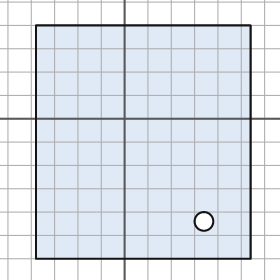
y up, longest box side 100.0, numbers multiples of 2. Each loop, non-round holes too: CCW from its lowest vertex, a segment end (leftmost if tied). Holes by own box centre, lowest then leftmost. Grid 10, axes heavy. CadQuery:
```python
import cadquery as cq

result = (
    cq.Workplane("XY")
    .moveTo(-38.0, -60.0)
    .lineTo(54.0, -60.0)
    .lineTo(54.0, 40.0)
    .lineTo(-38.0, 40.0)
    .close()
    .moveTo(34.0, -44.0)
    .circle(4.0)
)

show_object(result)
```